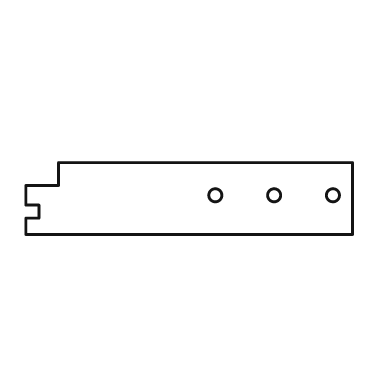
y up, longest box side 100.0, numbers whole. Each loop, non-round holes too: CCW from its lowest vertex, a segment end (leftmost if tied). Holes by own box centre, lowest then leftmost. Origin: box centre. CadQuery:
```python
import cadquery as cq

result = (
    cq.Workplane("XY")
    .moveTo(-50.0, -11.0)
    .lineTo(50.0, -11.0)
    .lineTo(50.0, 11.0)
    .lineTo(-40.0, 11.0)
    .lineTo(-40.0, 4.0)
    .lineTo(-50.0, 4.0)
    .lineTo(-50.0, -2.0)
    .lineTo(-46.0, -2.0)
    .lineTo(-46.0, -6.0)
    .lineTo(-50.0, -6.0)
    .close()
    .moveTo(8.0, 1.0)
    .circle(2.0)
    .moveTo(26.0, 1.0)
    .circle(2.0)
    .moveTo(44.0, 1.0)
    .circle(2.0)
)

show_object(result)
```